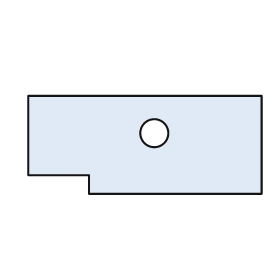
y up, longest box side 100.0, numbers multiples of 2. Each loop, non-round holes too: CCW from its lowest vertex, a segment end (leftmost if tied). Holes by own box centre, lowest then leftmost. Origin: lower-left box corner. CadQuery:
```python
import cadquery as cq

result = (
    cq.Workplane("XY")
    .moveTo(26.0, 0.0)
    .lineTo(100.0, 0.0)
    .lineTo(100.0, 42.0)
    .lineTo(0.0, 42.0)
    .lineTo(0.0, 8.0)
    .lineTo(26.0, 8.0)
    .close()
    .moveTo(54.0, 26.0)
    .circle(6.0)
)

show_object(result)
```